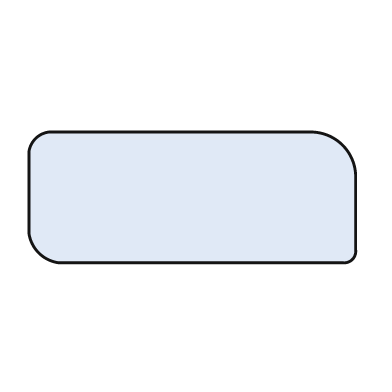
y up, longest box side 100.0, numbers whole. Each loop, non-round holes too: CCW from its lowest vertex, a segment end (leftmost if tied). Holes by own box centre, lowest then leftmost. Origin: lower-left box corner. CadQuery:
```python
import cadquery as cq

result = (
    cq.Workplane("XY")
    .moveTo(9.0, 0.0)
    .lineTo(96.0, 0.0)
    .threePointArc((99.0, 1.0), (100.0, 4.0))
    .lineTo(100.0, 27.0)
    .threePointArc((96.0, 36.0), (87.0, 40.0))
    .lineTo(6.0, 40.0)
    .threePointArc((2.0, 38.0), (0.0, 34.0))
    .lineTo(0.0, 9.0)
    .threePointArc((3.0, 3.0), (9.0, 0.0))
    .close()
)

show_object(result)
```